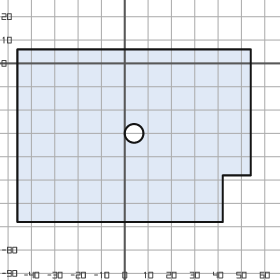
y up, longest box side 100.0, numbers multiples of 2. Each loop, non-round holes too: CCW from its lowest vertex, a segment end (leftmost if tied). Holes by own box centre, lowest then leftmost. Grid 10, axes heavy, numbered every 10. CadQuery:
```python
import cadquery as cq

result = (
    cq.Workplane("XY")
    .moveTo(-46.0, -68.0)
    .lineTo(42.0, -68.0)
    .lineTo(42.0, -48.0)
    .lineTo(54.0, -48.0)
    .lineTo(54.0, 6.0)
    .lineTo(-46.0, 6.0)
    .close()
    .moveTo(4.0, -30.0)
    .circle(4.0)
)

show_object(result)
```